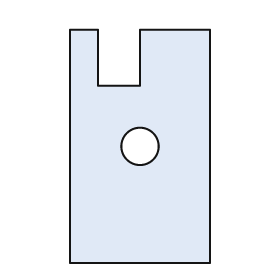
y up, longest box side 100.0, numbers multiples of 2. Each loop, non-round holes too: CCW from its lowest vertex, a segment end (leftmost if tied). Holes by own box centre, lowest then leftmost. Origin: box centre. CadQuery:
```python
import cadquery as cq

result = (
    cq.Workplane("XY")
    .moveTo(-30.0, -50.0)
    .lineTo(30.0, -50.0)
    .lineTo(30.0, 50.0)
    .lineTo(0.0, 50.0)
    .lineTo(0.0, 26.0)
    .lineTo(-18.0, 26.0)
    .lineTo(-18.0, 50.0)
    .lineTo(-30.0, 50.0)
    .close()
    .moveTo(0.0, 0.0)
    .circle(8.0)
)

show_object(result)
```